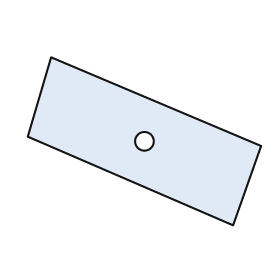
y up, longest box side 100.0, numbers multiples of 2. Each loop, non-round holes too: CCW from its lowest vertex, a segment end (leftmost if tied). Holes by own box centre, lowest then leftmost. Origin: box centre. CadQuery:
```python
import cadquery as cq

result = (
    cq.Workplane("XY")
    .moveTo(38.0, -36.0)
    .lineTo(50.0, -2.0)
    .lineTo(-40.0, 36.0)
    .lineTo(-50.0, 2.0)
    .close()
    .moveTo(0.0, 0.0)
    .circle(4.0)
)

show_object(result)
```